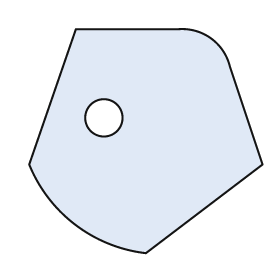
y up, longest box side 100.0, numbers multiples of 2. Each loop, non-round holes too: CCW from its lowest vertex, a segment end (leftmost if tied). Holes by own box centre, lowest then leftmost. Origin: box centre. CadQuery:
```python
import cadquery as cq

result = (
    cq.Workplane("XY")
    .moveTo(0.0, -48.0)
    .lineTo(50.0, -10.0)
    .lineTo(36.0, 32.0)
    .threePointArc((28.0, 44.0), (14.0, 48.0))
    .lineTo(-30.0, 48.0)
    .lineTo(-50.0, -10.0)
    .threePointArc((-30.0, -36.0), (0.0, -48.0))
    .close()
    .moveTo(-18.0, 10.0)
    .circle(8.0)
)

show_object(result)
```